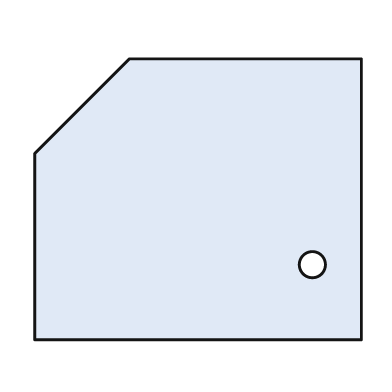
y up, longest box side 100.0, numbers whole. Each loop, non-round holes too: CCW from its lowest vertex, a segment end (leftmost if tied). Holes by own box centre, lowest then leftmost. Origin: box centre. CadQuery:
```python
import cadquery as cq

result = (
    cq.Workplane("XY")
    .moveTo(-50.0, -43.0)
    .lineTo(50.0, -43.0)
    .lineTo(50.0, 43.0)
    .lineTo(-21.0, 43.0)
    .lineTo(-50.0, 14.0)
    .close()
    .moveTo(35.0, -20.0)
    .circle(4.0)
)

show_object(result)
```